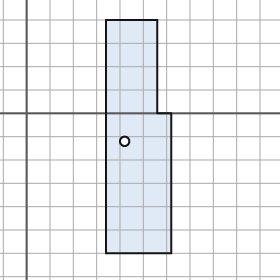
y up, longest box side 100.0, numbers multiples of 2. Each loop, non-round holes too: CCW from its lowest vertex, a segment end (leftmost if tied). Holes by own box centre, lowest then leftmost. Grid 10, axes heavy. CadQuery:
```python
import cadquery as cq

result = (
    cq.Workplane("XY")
    .moveTo(34.0, -60.0)
    .lineTo(62.0, -60.0)
    .lineTo(62.0, 0.0)
    .lineTo(56.0, 0.0)
    .lineTo(56.0, 40.0)
    .lineTo(34.0, 40.0)
    .close()
    .moveTo(42.0, -12.0)
    .circle(2.0)
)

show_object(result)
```